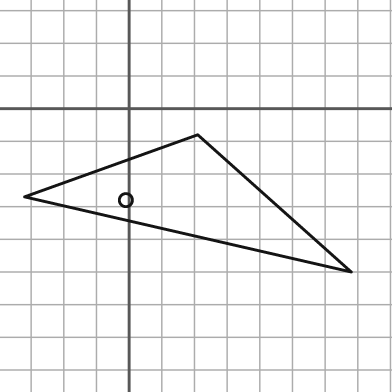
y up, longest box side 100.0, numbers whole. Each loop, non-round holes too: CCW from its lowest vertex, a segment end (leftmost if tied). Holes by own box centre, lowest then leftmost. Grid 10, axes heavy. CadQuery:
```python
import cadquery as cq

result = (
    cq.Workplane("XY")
    .moveTo(68.0, -50.0)
    .lineTo(21.0, -8.0)
    .lineTo(-32.0, -27.0)
    .close()
    .moveTo(-1.0, -28.0)
    .circle(2.0)
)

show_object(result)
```